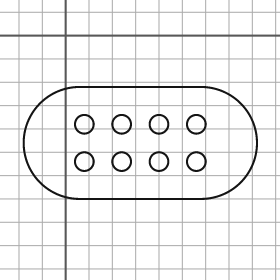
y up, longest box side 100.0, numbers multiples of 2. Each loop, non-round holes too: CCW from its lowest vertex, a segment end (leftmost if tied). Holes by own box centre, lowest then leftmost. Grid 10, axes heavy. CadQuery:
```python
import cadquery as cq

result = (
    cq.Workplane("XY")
    .moveTo(6.0, -70.0)
    .lineTo(58.0, -70.0)
    .threePointArc((82.0, -46.0), (58.0, -22.0))
    .lineTo(6.0, -22.0)
    .threePointArc((-18.0, -46.0), (6.0, -70.0))
    .close()
    .moveTo(8.0, -54.0)
    .circle(4.0)
    .moveTo(24.0, -54.0)
    .circle(4.0)
    .moveTo(40.0, -54.0)
    .circle(4.0)
    .moveTo(56.0, -54.0)
    .circle(4.0)
    .moveTo(8.0, -38.0)
    .circle(4.0)
    .moveTo(24.0, -38.0)
    .circle(4.0)
    .moveTo(40.0, -38.0)
    .circle(4.0)
    .moveTo(56.0, -38.0)
    .circle(4.0)
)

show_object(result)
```